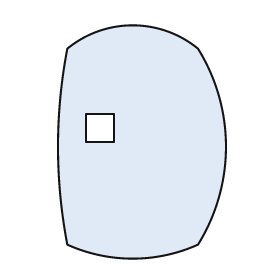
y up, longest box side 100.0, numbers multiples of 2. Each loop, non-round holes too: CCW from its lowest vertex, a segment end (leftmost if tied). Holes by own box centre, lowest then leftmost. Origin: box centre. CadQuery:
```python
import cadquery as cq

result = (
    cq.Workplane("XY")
    .moveTo(-32.0, -44.0)
    .threePointArc((-4.0, -50.0), (24.0, -44.0))
    .threePointArc((36.0, -2.0), (24.0, 40.0))
    .threePointArc((-4.0, 50.0), (-32.0, 40.0))
    .threePointArc((-36.0, -2.0), (-32.0, -44.0))
    .close()
    .moveTo(-24.0, 0.0)
    .lineTo(-12.0, 0.0)
    .lineTo(-12.0, 12.0)
    .lineTo(-24.0, 12.0)
    .close()
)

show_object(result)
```